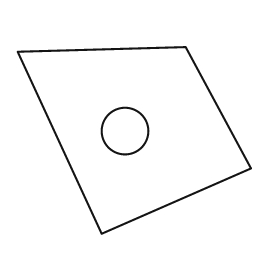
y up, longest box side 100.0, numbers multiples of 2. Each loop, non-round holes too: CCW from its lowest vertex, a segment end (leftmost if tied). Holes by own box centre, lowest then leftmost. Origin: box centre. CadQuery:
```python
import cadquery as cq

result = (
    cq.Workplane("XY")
    .moveTo(-14.0, -40.0)
    .lineTo(50.0, -12.0)
    .lineTo(22.0, 40.0)
    .lineTo(-50.0, 38.0)
    .close()
    .moveTo(-4.0, 4.0)
    .circle(10.0)
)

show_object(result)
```